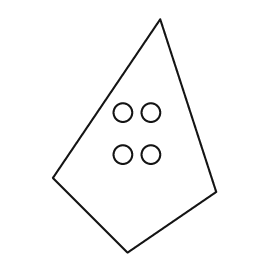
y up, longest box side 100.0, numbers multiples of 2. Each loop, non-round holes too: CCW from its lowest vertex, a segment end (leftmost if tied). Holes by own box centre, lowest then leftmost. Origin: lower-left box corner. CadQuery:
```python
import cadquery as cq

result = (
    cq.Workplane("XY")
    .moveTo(32.0, 0.0)
    .lineTo(70.0, 26.0)
    .lineTo(46.0, 100.0)
    .lineTo(0.0, 32.0)
    .close()
    .moveTo(30.0, 42.0)
    .circle(4.0)
    .moveTo(42.0, 42.0)
    .circle(4.0)
    .moveTo(30.0, 60.0)
    .circle(4.0)
    .moveTo(42.0, 60.0)
    .circle(4.0)
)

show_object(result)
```